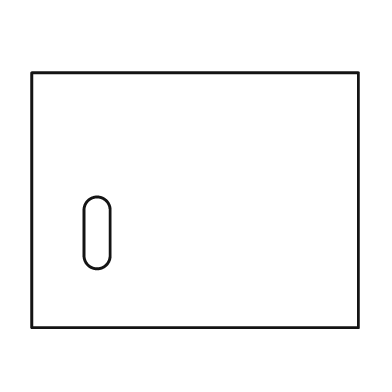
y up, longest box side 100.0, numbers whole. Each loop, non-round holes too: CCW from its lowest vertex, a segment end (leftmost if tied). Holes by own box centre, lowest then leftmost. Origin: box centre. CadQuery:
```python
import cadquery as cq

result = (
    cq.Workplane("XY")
    .moveTo(-50.0, -39.0)
    .lineTo(50.0, -39.0)
    .lineTo(50.0, 39.0)
    .lineTo(-50.0, 39.0)
    .close()
    .moveTo(-34.0, -17.0)
    .threePointArc((-30.0, -21.0), (-26.0, -17.0))
    .lineTo(-26.0, -3.0)
    .threePointArc((-30.0, 1.0), (-34.0, -3.0))
    .close()
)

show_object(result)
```